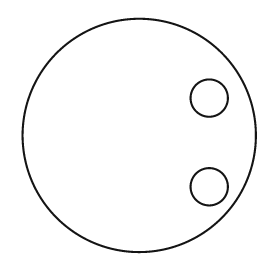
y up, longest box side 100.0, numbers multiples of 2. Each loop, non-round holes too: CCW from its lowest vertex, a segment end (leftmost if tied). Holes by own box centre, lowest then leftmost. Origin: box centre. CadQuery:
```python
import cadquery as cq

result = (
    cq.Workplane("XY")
    .moveTo(0.0, 0.0)
    .circle(50.0)
    .moveTo(30.0, -22.0)
    .circle(8.0)
    .moveTo(30.0, 16.0)
    .circle(8.0)
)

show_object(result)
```